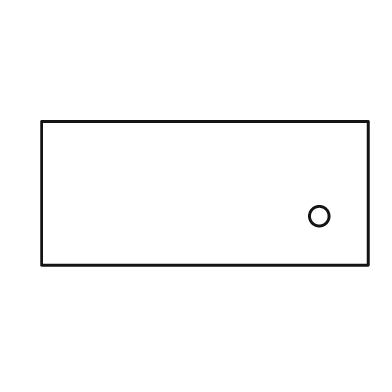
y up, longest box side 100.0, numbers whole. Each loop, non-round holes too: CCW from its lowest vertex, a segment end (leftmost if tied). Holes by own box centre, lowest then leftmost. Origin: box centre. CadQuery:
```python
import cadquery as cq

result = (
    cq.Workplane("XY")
    .moveTo(-50.0, -22.0)
    .lineTo(50.0, -22.0)
    .lineTo(50.0, 22.0)
    .lineTo(-50.0, 22.0)
    .close()
    .moveTo(35.0, -7.0)
    .circle(3.0)
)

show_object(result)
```